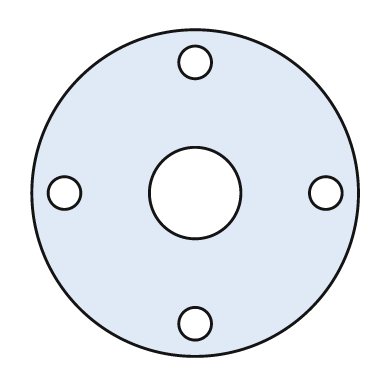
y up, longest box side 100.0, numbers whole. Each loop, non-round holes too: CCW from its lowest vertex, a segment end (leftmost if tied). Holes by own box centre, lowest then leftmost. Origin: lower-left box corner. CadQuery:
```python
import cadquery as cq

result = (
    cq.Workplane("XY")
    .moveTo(50.0, 50.0)
    .circle(50.0)
    .moveTo(50.0, 10.0)
    .circle(5.0)
    .moveTo(10.0, 50.0)
    .circle(5.0)
    .moveTo(50.0, 50.0)
    .circle(14.0)
    .moveTo(90.0, 50.0)
    .circle(5.0)
    .moveTo(50.0, 90.0)
    .circle(5.0)
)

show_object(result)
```